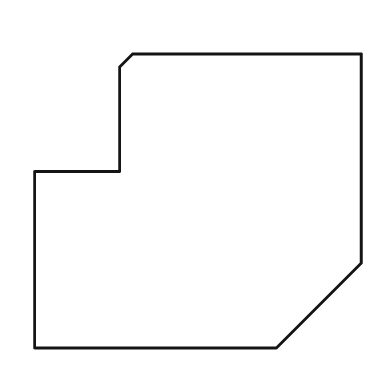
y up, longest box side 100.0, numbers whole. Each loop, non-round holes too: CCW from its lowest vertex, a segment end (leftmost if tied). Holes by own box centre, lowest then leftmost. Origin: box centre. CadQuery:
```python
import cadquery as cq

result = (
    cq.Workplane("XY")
    .moveTo(-50.0, -45.0)
    .lineTo(24.0, -45.0)
    .lineTo(50.0, -19.0)
    .lineTo(50.0, 45.0)
    .lineTo(-20.0, 45.0)
    .lineTo(-24.0, 41.0)
    .lineTo(-24.0, 9.0)
    .lineTo(-50.0, 9.0)
    .close()
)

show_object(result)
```